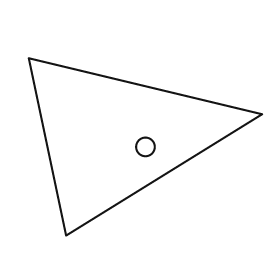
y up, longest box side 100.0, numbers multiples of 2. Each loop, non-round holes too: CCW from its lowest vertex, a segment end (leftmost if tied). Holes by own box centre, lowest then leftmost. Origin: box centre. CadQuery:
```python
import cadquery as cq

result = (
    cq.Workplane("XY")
    .moveTo(-34.0, -38.0)
    .lineTo(50.0, 14.0)
    .lineTo(-50.0, 38.0)
    .close()
    .moveTo(0.0, 0.0)
    .circle(4.0)
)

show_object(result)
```